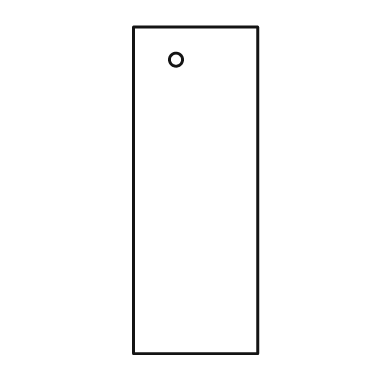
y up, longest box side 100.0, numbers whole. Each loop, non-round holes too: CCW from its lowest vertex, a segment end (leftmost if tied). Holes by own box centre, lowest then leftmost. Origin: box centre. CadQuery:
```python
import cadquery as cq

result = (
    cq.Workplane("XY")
    .moveTo(-19.0, -50.0)
    .lineTo(19.0, -50.0)
    .lineTo(19.0, 50.0)
    .lineTo(-19.0, 50.0)
    .close()
    .moveTo(-6.0, 40.0)
    .circle(2.0)
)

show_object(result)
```